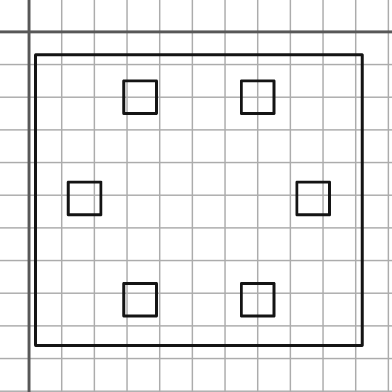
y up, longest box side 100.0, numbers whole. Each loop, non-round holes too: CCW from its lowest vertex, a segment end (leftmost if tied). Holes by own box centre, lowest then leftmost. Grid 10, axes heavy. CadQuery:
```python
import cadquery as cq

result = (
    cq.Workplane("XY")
    .moveTo(2.0, -96.0)
    .lineTo(102.0, -96.0)
    .lineTo(102.0, -7.0)
    .lineTo(2.0, -7.0)
    .close()
    .moveTo(29.0, -87.0)
    .lineTo(39.0, -87.0)
    .lineTo(39.0, -77.0)
    .lineTo(29.0, -77.0)
    .close()
    .moveTo(65.0, -87.0)
    .lineTo(75.0, -87.0)
    .lineTo(75.0, -77.0)
    .lineTo(65.0, -77.0)
    .close()
    .moveTo(12.0, -56.0)
    .lineTo(22.0, -56.0)
    .lineTo(22.0, -46.0)
    .lineTo(12.0, -46.0)
    .close()
    .moveTo(82.0, -56.0)
    .lineTo(92.0, -56.0)
    .lineTo(92.0, -46.0)
    .lineTo(82.0, -46.0)
    .close()
    .moveTo(29.0, -25.0)
    .lineTo(39.0, -25.0)
    .lineTo(39.0, -15.0)
    .lineTo(29.0, -15.0)
    .close()
    .moveTo(65.0, -25.0)
    .lineTo(75.0, -25.0)
    .lineTo(75.0, -15.0)
    .lineTo(65.0, -15.0)
    .close()
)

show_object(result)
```